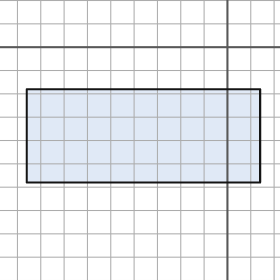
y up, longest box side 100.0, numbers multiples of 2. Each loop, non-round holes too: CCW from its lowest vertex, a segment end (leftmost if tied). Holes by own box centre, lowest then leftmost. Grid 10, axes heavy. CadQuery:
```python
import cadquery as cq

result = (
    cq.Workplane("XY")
    .moveTo(-86.0, -58.0)
    .lineTo(14.0, -58.0)
    .lineTo(14.0, -18.0)
    .lineTo(-86.0, -18.0)
    .close()
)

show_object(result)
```